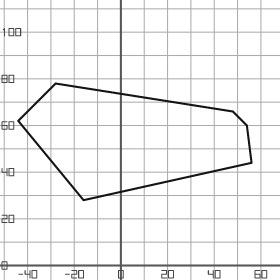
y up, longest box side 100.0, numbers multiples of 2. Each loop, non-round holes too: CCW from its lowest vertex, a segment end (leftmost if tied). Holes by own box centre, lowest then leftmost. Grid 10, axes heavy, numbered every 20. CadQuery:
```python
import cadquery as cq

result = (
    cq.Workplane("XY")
    .moveTo(-16.0, 28.0)
    .lineTo(56.0, 44.0)
    .lineTo(54.0, 60.0)
    .lineTo(48.0, 66.0)
    .lineTo(-28.0, 78.0)
    .lineTo(-44.0, 62.0)
    .close()
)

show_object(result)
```